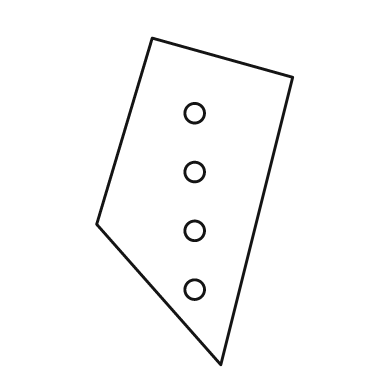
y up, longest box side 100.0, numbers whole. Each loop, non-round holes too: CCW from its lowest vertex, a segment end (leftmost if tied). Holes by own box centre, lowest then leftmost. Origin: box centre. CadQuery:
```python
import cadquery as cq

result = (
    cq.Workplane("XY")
    .moveTo(8.0, -50.0)
    .lineTo(30.0, 38.0)
    .lineTo(-13.0, 50.0)
    .lineTo(-30.0, -7.0)
    .close()
    .moveTo(0.0, -27.0)
    .circle(3.0)
    .moveTo(0.0, -9.0)
    .circle(3.0)
    .moveTo(0.0, 9.0)
    .circle(3.0)
    .moveTo(0.0, 27.0)
    .circle(3.0)
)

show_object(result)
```